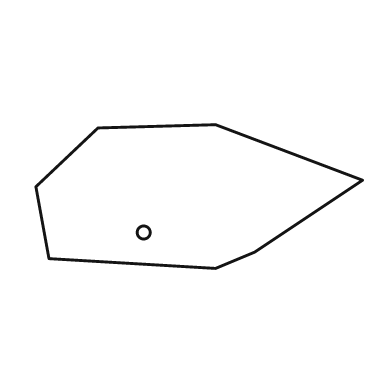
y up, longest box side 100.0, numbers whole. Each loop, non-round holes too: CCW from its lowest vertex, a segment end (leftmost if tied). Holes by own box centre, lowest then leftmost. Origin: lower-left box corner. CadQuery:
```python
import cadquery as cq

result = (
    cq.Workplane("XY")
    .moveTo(55.0, 0.0)
    .lineTo(67.0, 5.0)
    .lineTo(100.0, 27.0)
    .lineTo(55.0, 44.0)
    .lineTo(19.0, 43.0)
    .lineTo(0.0, 25.0)
    .lineTo(4.0, 3.0)
    .close()
    .moveTo(33.0, 11.0)
    .circle(2.0)
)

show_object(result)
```